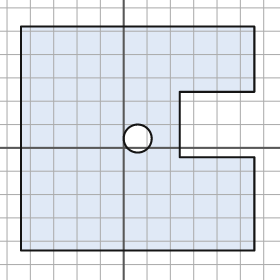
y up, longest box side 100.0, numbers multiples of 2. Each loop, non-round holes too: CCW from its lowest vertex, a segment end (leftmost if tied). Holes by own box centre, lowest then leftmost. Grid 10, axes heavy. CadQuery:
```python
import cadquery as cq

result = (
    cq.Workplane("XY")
    .moveTo(-44.0, -44.0)
    .lineTo(56.0, -44.0)
    .lineTo(56.0, -4.0)
    .lineTo(24.0, -4.0)
    .lineTo(24.0, 24.0)
    .lineTo(56.0, 24.0)
    .lineTo(56.0, 52.0)
    .lineTo(-44.0, 52.0)
    .close()
    .moveTo(6.0, 4.0)
    .circle(6.0)
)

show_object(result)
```